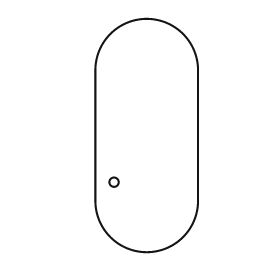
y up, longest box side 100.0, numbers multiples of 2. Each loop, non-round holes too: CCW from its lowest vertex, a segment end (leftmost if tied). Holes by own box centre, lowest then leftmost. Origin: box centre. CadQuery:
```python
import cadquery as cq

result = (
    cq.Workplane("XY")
    .moveTo(-22.0, -28.0)
    .threePointArc((0.0, -50.0), (22.0, -28.0))
    .lineTo(22.0, 28.0)
    .threePointArc((0.0, 50.0), (-22.0, 28.0))
    .close()
    .moveTo(-14.0, -20.0)
    .circle(2.0)
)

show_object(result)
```